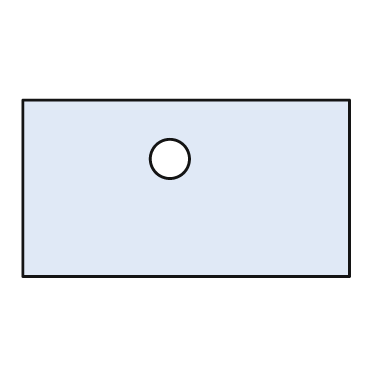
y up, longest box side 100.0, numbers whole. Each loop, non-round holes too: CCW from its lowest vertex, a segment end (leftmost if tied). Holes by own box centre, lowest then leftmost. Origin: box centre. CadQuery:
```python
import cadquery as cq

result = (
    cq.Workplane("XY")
    .moveTo(-50.0, -27.0)
    .lineTo(50.0, -27.0)
    .lineTo(50.0, 27.0)
    .lineTo(-50.0, 27.0)
    .close()
    .moveTo(-5.0, 9.0)
    .circle(6.0)
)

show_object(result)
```